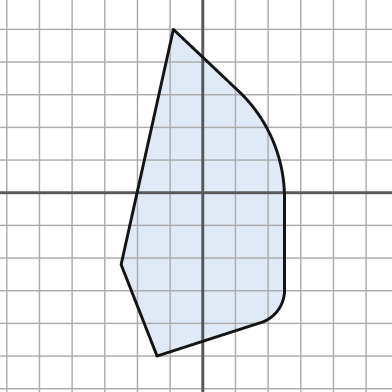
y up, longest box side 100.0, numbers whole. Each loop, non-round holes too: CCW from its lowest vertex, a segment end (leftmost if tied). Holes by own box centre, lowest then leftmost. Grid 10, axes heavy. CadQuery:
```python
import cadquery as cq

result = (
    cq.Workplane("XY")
    .moveTo(-14.0, -50.0)
    .lineTo(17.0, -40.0)
    .threePointArc((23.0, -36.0), (25.0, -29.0))
    .lineTo(25.0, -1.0)
    .threePointArc((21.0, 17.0), (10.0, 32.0))
    .lineTo(-9.0, 50.0)
    .lineTo(-25.0, -22.0)
    .close()
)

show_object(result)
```